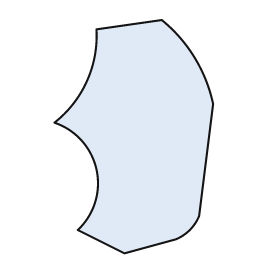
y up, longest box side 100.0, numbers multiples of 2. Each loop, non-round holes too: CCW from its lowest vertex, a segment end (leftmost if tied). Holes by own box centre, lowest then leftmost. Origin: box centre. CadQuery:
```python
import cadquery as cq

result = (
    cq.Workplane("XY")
    .moveTo(-4.0, -50.0)
    .lineTo(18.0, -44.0)
    .threePointArc((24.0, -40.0), (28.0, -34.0))
    .lineTo(34.0, 14.0)
    .threePointArc((26.0, 34.0), (12.0, 50.0))
    .lineTo(-16.0, 46.0)
    .threePointArc((-20.0, 24.0), (-34.0, 6.0))
    .threePointArc((-16.0, -14.0), (-24.0, -40.0))
    .close()
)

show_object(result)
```